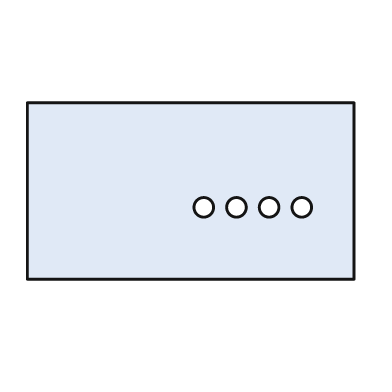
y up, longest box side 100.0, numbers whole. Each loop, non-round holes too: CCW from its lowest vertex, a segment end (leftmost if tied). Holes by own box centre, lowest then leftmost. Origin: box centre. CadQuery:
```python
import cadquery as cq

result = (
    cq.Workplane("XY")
    .moveTo(-50.0, -27.0)
    .lineTo(50.0, -27.0)
    .lineTo(50.0, 27.0)
    .lineTo(-50.0, 27.0)
    .close()
    .moveTo(4.0, -5.0)
    .circle(3.0)
    .moveTo(14.0, -5.0)
    .circle(3.0)
    .moveTo(24.0, -5.0)
    .circle(3.0)
    .moveTo(34.0, -5.0)
    .circle(3.0)
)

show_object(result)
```